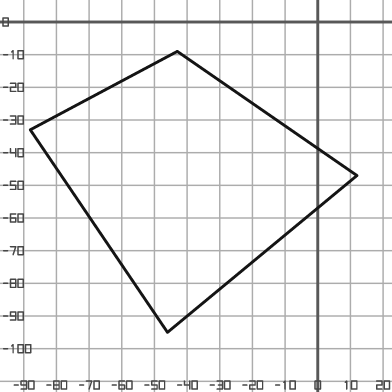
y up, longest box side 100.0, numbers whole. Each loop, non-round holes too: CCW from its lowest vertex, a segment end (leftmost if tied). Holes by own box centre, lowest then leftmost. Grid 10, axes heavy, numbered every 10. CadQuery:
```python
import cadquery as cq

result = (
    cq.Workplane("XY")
    .moveTo(-46.0, -95.0)
    .lineTo(12.0, -47.0)
    .lineTo(-43.0, -9.0)
    .lineTo(-88.0, -33.0)
    .close()
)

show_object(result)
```